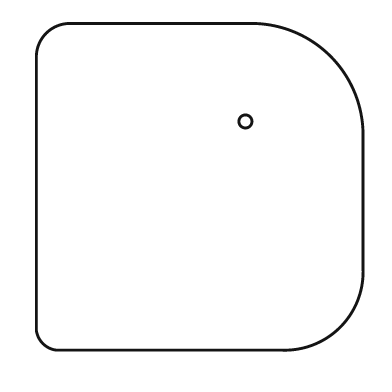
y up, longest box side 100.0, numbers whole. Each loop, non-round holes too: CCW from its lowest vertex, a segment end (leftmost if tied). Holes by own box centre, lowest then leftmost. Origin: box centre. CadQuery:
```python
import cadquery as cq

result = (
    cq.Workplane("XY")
    .moveTo(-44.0, -50.0)
    .lineTo(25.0, -50.0)
    .threePointArc((43.0, -43.0), (50.0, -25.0))
    .lineTo(50.0, 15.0)
    .threePointArc((40.0, 40.0), (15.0, 50.0))
    .lineTo(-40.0, 50.0)
    .threePointArc((-47.0, 47.0), (-50.0, 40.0))
    .lineTo(-50.0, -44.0)
    .threePointArc((-48.0, -48.0), (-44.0, -50.0))
    .close()
    .moveTo(14.0, 20.0)
    .circle(2.0)
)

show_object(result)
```